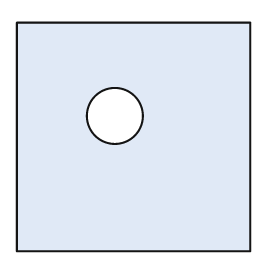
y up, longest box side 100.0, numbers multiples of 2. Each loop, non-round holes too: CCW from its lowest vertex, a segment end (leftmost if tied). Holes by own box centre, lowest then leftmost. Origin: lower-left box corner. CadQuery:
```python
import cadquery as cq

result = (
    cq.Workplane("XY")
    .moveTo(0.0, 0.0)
    .lineTo(100.0, 0.0)
    .lineTo(100.0, 98.0)
    .lineTo(0.0, 98.0)
    .close()
    .moveTo(42.0, 58.0)
    .circle(12.0)
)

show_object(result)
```